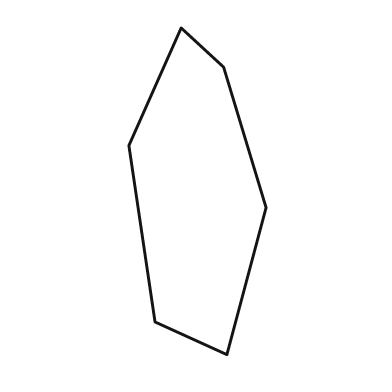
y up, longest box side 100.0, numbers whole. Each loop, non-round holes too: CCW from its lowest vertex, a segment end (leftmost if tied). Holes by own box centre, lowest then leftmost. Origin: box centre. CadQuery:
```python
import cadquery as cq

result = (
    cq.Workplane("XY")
    .moveTo(9.0, -50.0)
    .lineTo(21.0, -5.0)
    .lineTo(8.0, 38.0)
    .lineTo(-5.0, 50.0)
    .lineTo(-21.0, 14.0)
    .lineTo(-13.0, -40.0)
    .close()
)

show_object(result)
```